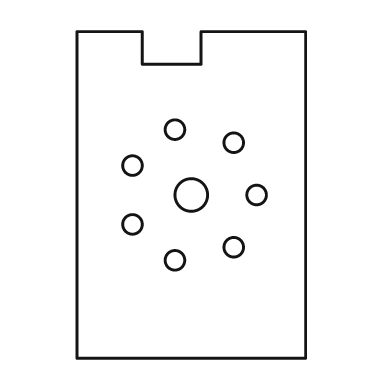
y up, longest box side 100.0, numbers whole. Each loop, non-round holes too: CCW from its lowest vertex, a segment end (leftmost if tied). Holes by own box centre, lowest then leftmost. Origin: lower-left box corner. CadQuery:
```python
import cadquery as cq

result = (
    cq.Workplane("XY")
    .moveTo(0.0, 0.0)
    .lineTo(70.0, 0.0)
    .lineTo(70.0, 100.0)
    .lineTo(38.0, 100.0)
    .lineTo(38.0, 90.0)
    .lineTo(20.0, 90.0)
    .lineTo(20.0, 100.0)
    .lineTo(0.0, 100.0)
    .close()
    .moveTo(30.0, 30.0)
    .circle(3.0)
    .moveTo(48.0, 34.0)
    .circle(3.0)
    .moveTo(17.0, 41.0)
    .circle(3.0)
    .moveTo(35.0, 50.0)
    .circle(5.0)
    .moveTo(55.0, 50.0)
    .circle(3.0)
    .moveTo(17.0, 59.0)
    .circle(3.0)
    .moveTo(48.0, 66.0)
    .circle(3.0)
    .moveTo(30.0, 70.0)
    .circle(3.0)
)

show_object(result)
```